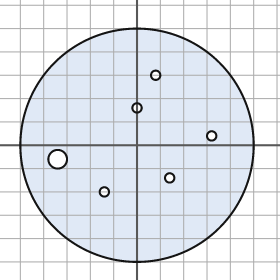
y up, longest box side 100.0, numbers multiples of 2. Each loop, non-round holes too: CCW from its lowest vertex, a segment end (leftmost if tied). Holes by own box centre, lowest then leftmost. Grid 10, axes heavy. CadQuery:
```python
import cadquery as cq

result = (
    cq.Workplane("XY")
    .moveTo(0.0, 0.0)
    .circle(50.0)
    .moveTo(-14.0, -20.0)
    .circle(2.0)
    .moveTo(14.0, -14.0)
    .circle(2.0)
    .moveTo(-34.0, -6.0)
    .circle(4.0)
    .moveTo(32.0, 4.0)
    .circle(2.0)
    .moveTo(0.0, 16.0)
    .circle(2.0)
    .moveTo(8.0, 30.0)
    .circle(2.0)
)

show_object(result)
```